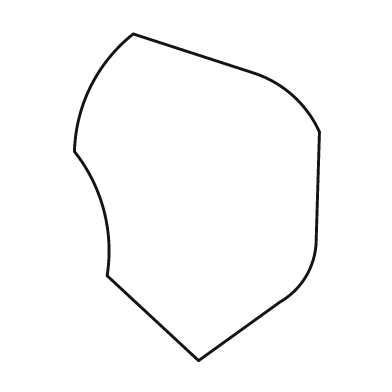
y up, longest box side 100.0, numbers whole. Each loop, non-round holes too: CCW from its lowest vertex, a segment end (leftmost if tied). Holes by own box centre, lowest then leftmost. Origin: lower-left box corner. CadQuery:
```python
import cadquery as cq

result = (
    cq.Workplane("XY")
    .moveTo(38.0, 0.0)
    .lineTo(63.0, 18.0)
    .threePointArc((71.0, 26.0), (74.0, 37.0))
    .lineTo(75.0, 70.0)
    .threePointArc((67.0, 81.0), (55.0, 88.0))
    .lineTo(18.0, 100.0)
    .threePointArc((5.0, 84.0), (0.0, 64.0))
    .threePointArc((9.0, 46.0), (10.0, 26.0))
    .close()
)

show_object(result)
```